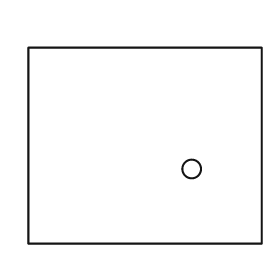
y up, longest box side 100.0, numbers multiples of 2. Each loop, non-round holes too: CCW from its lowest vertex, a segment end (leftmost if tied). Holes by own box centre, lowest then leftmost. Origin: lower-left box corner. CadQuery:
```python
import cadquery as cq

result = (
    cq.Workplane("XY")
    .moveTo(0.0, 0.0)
    .lineTo(100.0, 0.0)
    .lineTo(100.0, 84.0)
    .lineTo(0.0, 84.0)
    .close()
    .moveTo(70.0, 32.0)
    .circle(4.0)
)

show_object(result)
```